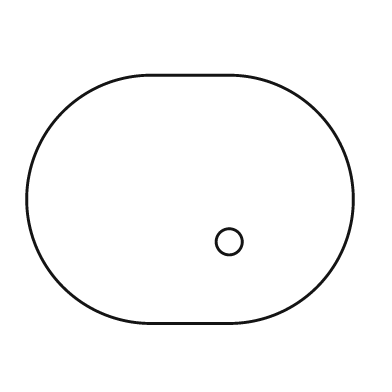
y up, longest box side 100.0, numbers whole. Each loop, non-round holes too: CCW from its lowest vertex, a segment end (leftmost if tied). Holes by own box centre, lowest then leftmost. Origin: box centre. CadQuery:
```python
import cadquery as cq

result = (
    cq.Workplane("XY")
    .moveTo(-12.0, -38.0)
    .lineTo(12.0, -38.0)
    .threePointArc((50.0, 0.0), (12.0, 38.0))
    .lineTo(-12.0, 38.0)
    .threePointArc((-50.0, 0.0), (-12.0, -38.0))
    .close()
    .moveTo(12.0, -13.0)
    .circle(4.0)
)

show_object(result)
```